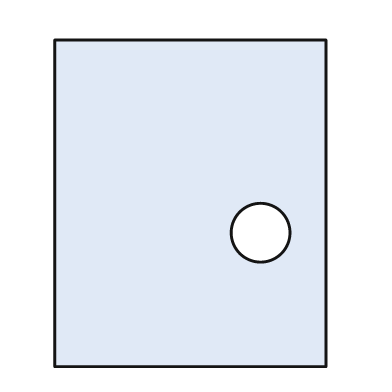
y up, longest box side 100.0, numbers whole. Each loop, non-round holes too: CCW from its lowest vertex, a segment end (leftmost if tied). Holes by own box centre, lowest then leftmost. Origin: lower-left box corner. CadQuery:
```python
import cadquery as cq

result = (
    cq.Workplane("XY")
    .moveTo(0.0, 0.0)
    .lineTo(83.0, 0.0)
    .lineTo(83.0, 100.0)
    .lineTo(0.0, 100.0)
    .close()
    .moveTo(63.0, 41.0)
    .circle(9.0)
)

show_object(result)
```